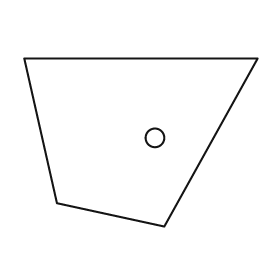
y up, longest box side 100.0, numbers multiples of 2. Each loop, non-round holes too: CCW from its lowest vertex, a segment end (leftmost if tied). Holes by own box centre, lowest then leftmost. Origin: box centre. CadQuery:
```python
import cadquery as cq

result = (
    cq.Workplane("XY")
    .moveTo(10.0, -36.0)
    .lineTo(50.0, 36.0)
    .lineTo(-50.0, 36.0)
    .lineTo(-36.0, -26.0)
    .close()
    .moveTo(6.0, 2.0)
    .circle(4.0)
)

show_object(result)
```